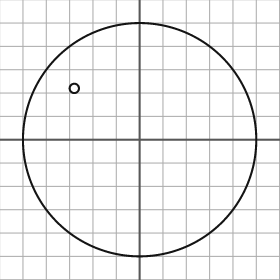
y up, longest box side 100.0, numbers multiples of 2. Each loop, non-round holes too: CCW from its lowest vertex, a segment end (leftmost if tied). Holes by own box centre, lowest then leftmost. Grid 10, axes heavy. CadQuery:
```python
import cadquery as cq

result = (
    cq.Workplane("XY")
    .moveTo(0.0, 0.0)
    .circle(50.0)
    .moveTo(-28.0, 22.0)
    .circle(2.0)
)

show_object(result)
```